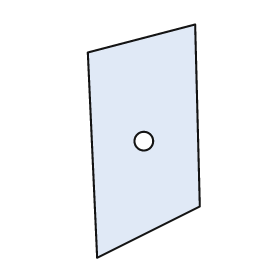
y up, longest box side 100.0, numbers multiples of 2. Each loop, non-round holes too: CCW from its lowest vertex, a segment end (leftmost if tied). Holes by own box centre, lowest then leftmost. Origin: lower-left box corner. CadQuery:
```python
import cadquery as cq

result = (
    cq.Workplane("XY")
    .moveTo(4.0, 0.0)
    .lineTo(48.0, 22.0)
    .lineTo(46.0, 100.0)
    .lineTo(0.0, 88.0)
    .close()
    .moveTo(24.0, 50.0)
    .circle(4.0)
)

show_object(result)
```